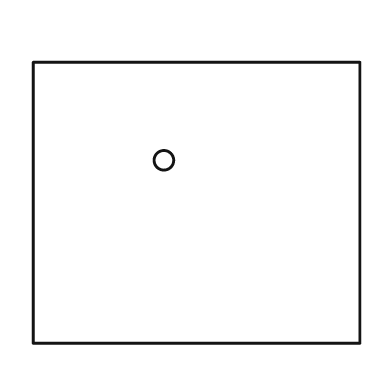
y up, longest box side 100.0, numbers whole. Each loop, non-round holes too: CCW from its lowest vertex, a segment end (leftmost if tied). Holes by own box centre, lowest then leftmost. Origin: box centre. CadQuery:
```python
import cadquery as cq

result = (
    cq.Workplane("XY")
    .moveTo(-50.0, -43.0)
    .lineTo(50.0, -43.0)
    .lineTo(50.0, 43.0)
    .lineTo(-50.0, 43.0)
    .close()
    .moveTo(-10.0, 13.0)
    .circle(3.0)
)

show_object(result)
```